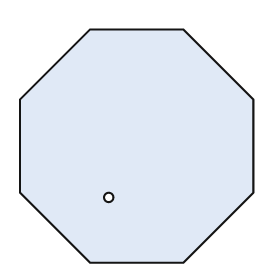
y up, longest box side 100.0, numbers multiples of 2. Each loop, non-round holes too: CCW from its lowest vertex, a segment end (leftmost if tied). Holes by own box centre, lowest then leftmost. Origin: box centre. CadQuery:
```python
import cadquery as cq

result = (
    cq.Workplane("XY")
    .moveTo(-20.0, -50.0)
    .lineTo(20.0, -50.0)
    .lineTo(50.0, -20.0)
    .lineTo(50.0, 20.0)
    .lineTo(20.0, 50.0)
    .lineTo(-20.0, 50.0)
    .lineTo(-50.0, 20.0)
    .lineTo(-50.0, -20.0)
    .close()
    .moveTo(-12.0, -22.0)
    .circle(2.0)
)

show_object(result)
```